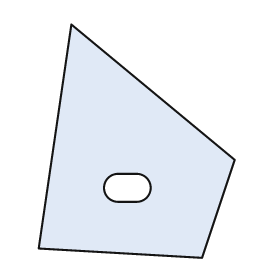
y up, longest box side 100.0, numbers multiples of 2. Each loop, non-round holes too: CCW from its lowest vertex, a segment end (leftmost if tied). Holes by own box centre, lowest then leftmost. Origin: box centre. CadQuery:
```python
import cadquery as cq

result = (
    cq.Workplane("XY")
    .moveTo(28.0, -50.0)
    .lineTo(42.0, -8.0)
    .lineTo(-28.0, 50.0)
    .lineTo(-42.0, -46.0)
    .close()
    .moveTo(-8.0, -26.0)
    .lineTo(0.0, -26.0)
    .threePointArc((6.0, -20.0), (0.0, -14.0))
    .lineTo(-8.0, -14.0)
    .threePointArc((-14.0, -20.0), (-8.0, -26.0))
    .close()
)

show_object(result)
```